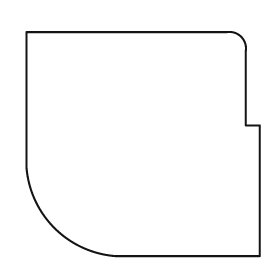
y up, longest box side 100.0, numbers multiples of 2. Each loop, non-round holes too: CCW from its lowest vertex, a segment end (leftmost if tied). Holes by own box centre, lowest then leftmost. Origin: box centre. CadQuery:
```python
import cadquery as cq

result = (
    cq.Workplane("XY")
    .moveTo(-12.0, -48.0)
    .lineTo(50.0, -48.0)
    .lineTo(50.0, 8.0)
    .lineTo(44.0, 8.0)
    .lineTo(44.0, 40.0)
    .threePointArc((42.0, 46.0), (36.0, 48.0))
    .lineTo(-50.0, 48.0)
    .lineTo(-50.0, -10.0)
    .threePointArc((-38.0, -36.0), (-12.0, -48.0))
    .close()
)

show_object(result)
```